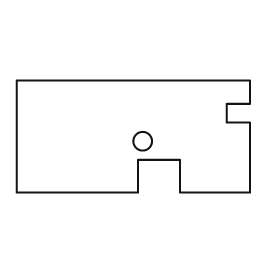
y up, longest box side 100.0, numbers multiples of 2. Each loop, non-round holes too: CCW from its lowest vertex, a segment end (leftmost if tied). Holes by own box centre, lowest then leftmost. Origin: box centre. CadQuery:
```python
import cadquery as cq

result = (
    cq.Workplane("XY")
    .moveTo(-50.0, -24.0)
    .lineTo(2.0, -24.0)
    .lineTo(2.0, -10.0)
    .lineTo(20.0, -10.0)
    .lineTo(20.0, -24.0)
    .lineTo(50.0, -24.0)
    .lineTo(50.0, 6.0)
    .lineTo(40.0, 6.0)
    .lineTo(40.0, 14.0)
    .lineTo(50.0, 14.0)
    .lineTo(50.0, 24.0)
    .lineTo(-50.0, 24.0)
    .close()
    .moveTo(4.0, -2.0)
    .circle(4.0)
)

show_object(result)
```